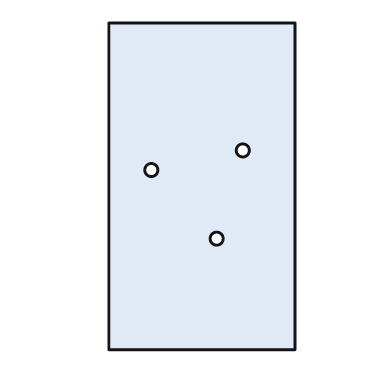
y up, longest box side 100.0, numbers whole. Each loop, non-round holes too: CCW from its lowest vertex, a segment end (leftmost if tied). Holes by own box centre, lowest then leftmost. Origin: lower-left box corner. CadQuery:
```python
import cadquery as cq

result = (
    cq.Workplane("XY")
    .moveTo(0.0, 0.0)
    .lineTo(57.0, 0.0)
    .lineTo(57.0, 100.0)
    .lineTo(0.0, 100.0)
    .close()
    .moveTo(33.0, 34.0)
    .circle(2.0)
    .moveTo(13.0, 55.0)
    .circle(2.0)
    .moveTo(41.0, 61.0)
    .circle(2.0)
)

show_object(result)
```